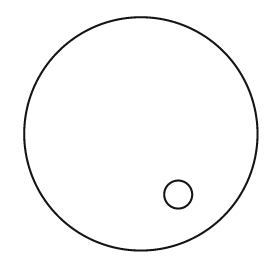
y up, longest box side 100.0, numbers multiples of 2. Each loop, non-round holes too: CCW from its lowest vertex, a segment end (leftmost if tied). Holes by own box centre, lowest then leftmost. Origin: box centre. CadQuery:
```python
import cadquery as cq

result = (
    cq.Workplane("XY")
    .moveTo(0.0, 0.0)
    .circle(50.0)
    .moveTo(16.0, -26.0)
    .circle(6.0)
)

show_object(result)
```